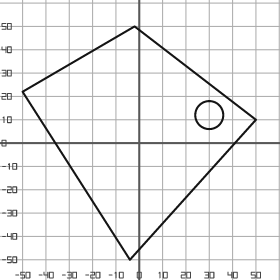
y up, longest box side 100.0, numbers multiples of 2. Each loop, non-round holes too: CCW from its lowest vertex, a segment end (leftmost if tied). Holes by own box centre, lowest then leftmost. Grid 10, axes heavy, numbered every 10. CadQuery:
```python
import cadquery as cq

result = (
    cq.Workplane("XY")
    .moveTo(-4.0, -50.0)
    .lineTo(50.0, 10.0)
    .lineTo(-2.0, 50.0)
    .lineTo(-50.0, 22.0)
    .close()
    .moveTo(30.0, 12.0)
    .circle(6.0)
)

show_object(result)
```